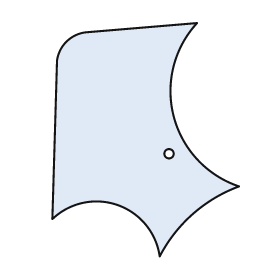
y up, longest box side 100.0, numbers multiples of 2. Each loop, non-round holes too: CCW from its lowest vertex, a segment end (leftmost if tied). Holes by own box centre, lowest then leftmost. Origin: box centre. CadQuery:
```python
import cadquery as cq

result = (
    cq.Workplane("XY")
    .moveTo(6.0, -50.0)
    .threePointArc((20.0, -32.0), (40.0, -20.0))
    .threePointArc((12.0, 10.0), (22.0, 50.0))
    .lineTo(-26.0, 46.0)
    .threePointArc((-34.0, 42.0), (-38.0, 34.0))
    .lineTo(-40.0, -34.0)
    .threePointArc((-12.0, -28.0), (6.0, -50.0))
    .close()
    .moveTo(10.0, -6.0)
    .circle(2.0)
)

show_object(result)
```